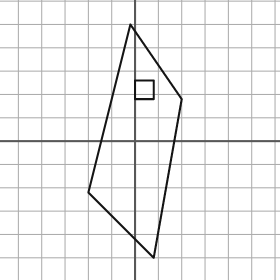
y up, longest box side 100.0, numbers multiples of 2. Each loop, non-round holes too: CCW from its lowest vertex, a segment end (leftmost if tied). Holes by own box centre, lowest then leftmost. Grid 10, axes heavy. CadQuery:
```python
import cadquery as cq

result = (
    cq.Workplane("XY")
    .moveTo(8.0, -50.0)
    .lineTo(20.0, 18.0)
    .lineTo(-2.0, 50.0)
    .lineTo(-20.0, -22.0)
    .close()
    .moveTo(0.0, 18.0)
    .lineTo(8.0, 18.0)
    .lineTo(8.0, 26.0)
    .lineTo(0.0, 26.0)
    .close()
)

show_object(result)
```